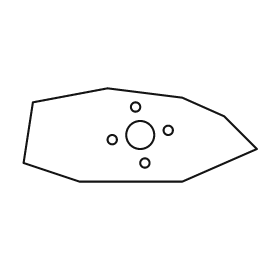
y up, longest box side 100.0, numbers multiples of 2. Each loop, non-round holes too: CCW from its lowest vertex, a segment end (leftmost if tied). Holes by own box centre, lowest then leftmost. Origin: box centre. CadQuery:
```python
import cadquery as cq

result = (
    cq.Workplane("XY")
    .moveTo(-26.0, -20.0)
    .lineTo(18.0, -20.0)
    .lineTo(50.0, -6.0)
    .lineTo(36.0, 8.0)
    .lineTo(18.0, 16.0)
    .lineTo(-14.0, 20.0)
    .lineTo(-46.0, 14.0)
    .lineTo(-50.0, -12.0)
    .close()
    .moveTo(2.0, -12.0)
    .circle(2.0)
    .moveTo(-12.0, -2.0)
    .circle(2.0)
    .moveTo(0.0, 0.0)
    .circle(6.0)
    .moveTo(12.0, 2.0)
    .circle(2.0)
    .moveTo(-2.0, 12.0)
    .circle(2.0)
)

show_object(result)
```